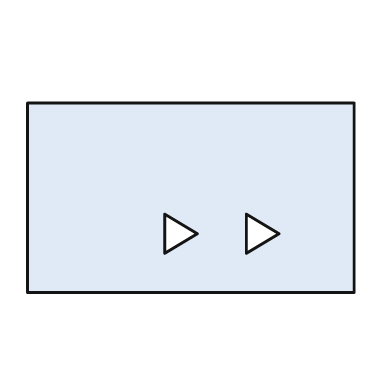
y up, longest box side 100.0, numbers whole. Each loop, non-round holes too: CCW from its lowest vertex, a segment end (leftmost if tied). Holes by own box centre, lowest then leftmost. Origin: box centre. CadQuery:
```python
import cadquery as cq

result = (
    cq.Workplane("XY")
    .moveTo(-50.0, -29.0)
    .lineTo(50.0, -29.0)
    .lineTo(50.0, 29.0)
    .lineTo(-50.0, 29.0)
    .close()
    .moveTo(-8.0, -17.0)
    .lineTo(2.0, -11.0)
    .lineTo(-8.0, -5.0)
    .close()
    .moveTo(17.0, -17.0)
    .lineTo(27.0, -11.0)
    .lineTo(17.0, -5.0)
    .close()
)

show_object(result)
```